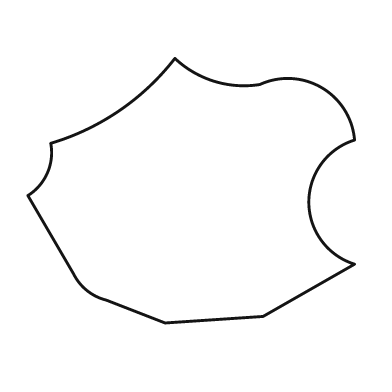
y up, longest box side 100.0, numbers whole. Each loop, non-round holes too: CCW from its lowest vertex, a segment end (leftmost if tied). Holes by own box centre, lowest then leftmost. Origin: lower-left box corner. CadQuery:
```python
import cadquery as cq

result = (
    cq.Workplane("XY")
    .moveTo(42.0, 0.0)
    .lineTo(72.0, 2.0)
    .lineTo(100.0, 18.0)
    .threePointArc((86.0, 37.0), (100.0, 56.0))
    .threePointArc((90.0, 72.0), (71.0, 73.0))
    .threePointArc((57.0, 74.0), (45.0, 81.0))
    .threePointArc((28.0, 65.0), (7.0, 55.0))
    .threePointArc((6.0, 46.0), (0.0, 39.0))
    .lineTo(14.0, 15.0)
    .threePointArc((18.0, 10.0), (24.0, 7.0))
    .close()
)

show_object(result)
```